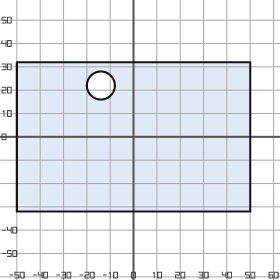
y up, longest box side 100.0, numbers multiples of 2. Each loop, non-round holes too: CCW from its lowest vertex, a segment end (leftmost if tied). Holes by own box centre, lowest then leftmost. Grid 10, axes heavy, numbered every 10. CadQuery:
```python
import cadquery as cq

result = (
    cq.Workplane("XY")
    .moveTo(-50.0, -32.0)
    .lineTo(50.0, -32.0)
    .lineTo(50.0, 32.0)
    .lineTo(-50.0, 32.0)
    .close()
    .moveTo(-14.0, 22.0)
    .circle(6.0)
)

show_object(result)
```